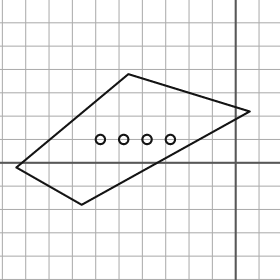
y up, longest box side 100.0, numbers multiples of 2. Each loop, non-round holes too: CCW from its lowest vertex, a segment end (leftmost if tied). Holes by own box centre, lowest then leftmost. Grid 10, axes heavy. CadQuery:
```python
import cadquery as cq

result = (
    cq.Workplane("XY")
    .moveTo(-66.0, -18.0)
    .lineTo(6.0, 22.0)
    .lineTo(-46.0, 38.0)
    .lineTo(-94.0, -2.0)
    .close()
    .moveTo(-58.0, 10.0)
    .circle(2.0)
    .moveTo(-48.0, 10.0)
    .circle(2.0)
    .moveTo(-38.0, 10.0)
    .circle(2.0)
    .moveTo(-28.0, 10.0)
    .circle(2.0)
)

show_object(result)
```